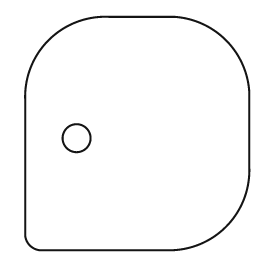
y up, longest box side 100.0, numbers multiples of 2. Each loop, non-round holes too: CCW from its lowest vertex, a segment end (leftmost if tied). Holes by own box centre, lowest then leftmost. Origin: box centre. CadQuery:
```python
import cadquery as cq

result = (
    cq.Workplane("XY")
    .moveTo(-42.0, -50.0)
    .lineTo(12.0, -50.0)
    .threePointArc((38.0, -40.0), (48.0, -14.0))
    .lineTo(48.0, 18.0)
    .threePointArc((38.0, 40.0), (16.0, 50.0))
    .lineTo(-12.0, 50.0)
    .threePointArc((-38.0, 40.0), (-48.0, 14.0))
    .lineTo(-48.0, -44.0)
    .threePointArc((-46.0, -48.0), (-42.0, -50.0))
    .close()
    .moveTo(-26.0, -2.0)
    .circle(6.0)
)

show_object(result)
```